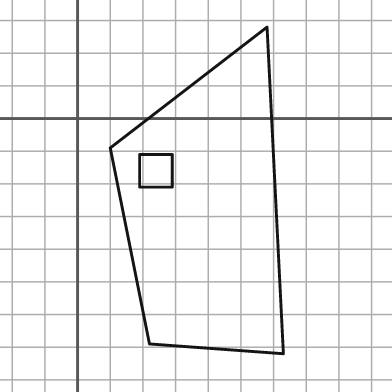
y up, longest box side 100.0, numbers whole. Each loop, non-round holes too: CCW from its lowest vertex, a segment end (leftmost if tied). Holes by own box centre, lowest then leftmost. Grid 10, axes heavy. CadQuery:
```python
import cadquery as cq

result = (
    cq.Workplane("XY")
    .moveTo(63.0, -72.0)
    .lineTo(58.0, 28.0)
    .lineTo(10.0, -9.0)
    .lineTo(22.0, -69.0)
    .close()
    .moveTo(19.0, -21.0)
    .lineTo(29.0, -21.0)
    .lineTo(29.0, -11.0)
    .lineTo(19.0, -11.0)
    .close()
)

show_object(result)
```